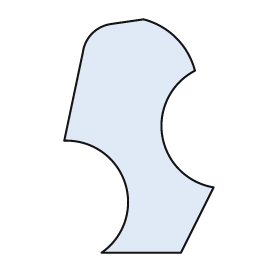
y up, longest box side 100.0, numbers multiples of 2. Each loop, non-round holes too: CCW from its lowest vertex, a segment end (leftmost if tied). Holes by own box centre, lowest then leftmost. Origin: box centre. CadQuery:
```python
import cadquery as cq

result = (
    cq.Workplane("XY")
    .moveTo(-16.0, -50.0)
    .lineTo(18.0, -50.0)
    .lineTo(32.0, -22.0)
    .threePointArc((10.0, 0.0), (24.0, 28.0))
    .threePointArc((16.0, 42.0), (2.0, 50.0))
    .lineTo(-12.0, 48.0)
    .threePointArc((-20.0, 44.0), (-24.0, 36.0))
    .lineTo(-32.0, -2.0)
    .threePointArc((-6.0, -20.0), (-16.0, -50.0))
    .close()
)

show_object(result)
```